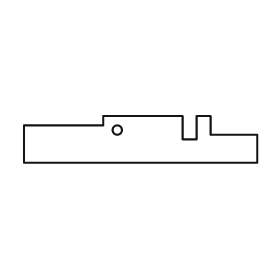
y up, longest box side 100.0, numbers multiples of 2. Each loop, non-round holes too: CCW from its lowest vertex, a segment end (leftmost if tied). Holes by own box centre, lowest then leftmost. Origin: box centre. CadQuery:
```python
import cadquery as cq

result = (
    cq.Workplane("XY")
    .moveTo(-50.0, -10.0)
    .lineTo(50.0, -10.0)
    .lineTo(50.0, 2.0)
    .lineTo(30.0, 2.0)
    .lineTo(30.0, 10.0)
    .lineTo(24.0, 10.0)
    .lineTo(24.0, 0.0)
    .lineTo(18.0, 0.0)
    .lineTo(18.0, 10.0)
    .lineTo(-16.0, 10.0)
    .lineTo(-16.0, 6.0)
    .lineTo(-50.0, 6.0)
    .close()
    .moveTo(-10.0, 4.0)
    .circle(2.0)
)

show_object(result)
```